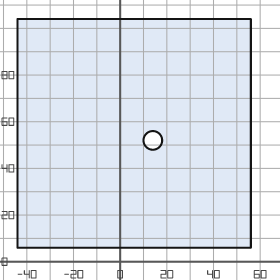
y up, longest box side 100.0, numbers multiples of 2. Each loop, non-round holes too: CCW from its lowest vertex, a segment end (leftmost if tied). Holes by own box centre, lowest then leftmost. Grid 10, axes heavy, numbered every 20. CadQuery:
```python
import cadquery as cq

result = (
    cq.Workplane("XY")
    .moveTo(-44.0, 6.0)
    .lineTo(56.0, 6.0)
    .lineTo(56.0, 104.0)
    .lineTo(-44.0, 104.0)
    .close()
    .moveTo(14.0, 52.0)
    .circle(4.0)
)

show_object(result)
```